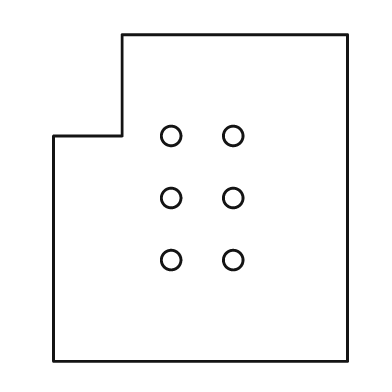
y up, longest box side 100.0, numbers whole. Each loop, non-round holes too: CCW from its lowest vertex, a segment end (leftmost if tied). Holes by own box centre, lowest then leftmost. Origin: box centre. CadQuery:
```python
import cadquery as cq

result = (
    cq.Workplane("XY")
    .moveTo(-45.0, -50.0)
    .lineTo(45.0, -50.0)
    .lineTo(45.0, 50.0)
    .lineTo(-24.0, 50.0)
    .lineTo(-24.0, 19.0)
    .lineTo(-45.0, 19.0)
    .close()
    .moveTo(-9.0, -19.0)
    .circle(3.0)
    .moveTo(10.0, -19.0)
    .circle(3.0)
    .moveTo(-9.0, 0.0)
    .circle(3.0)
    .moveTo(10.0, 0.0)
    .circle(3.0)
    .moveTo(-9.0, 19.0)
    .circle(3.0)
    .moveTo(10.0, 19.0)
    .circle(3.0)
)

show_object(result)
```